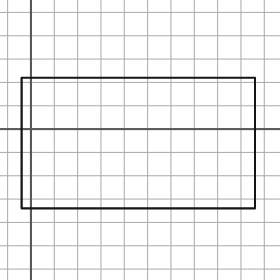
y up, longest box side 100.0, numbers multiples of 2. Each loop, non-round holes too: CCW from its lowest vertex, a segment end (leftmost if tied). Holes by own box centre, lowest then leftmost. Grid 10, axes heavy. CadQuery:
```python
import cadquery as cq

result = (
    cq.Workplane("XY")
    .moveTo(-4.0, -34.0)
    .lineTo(96.0, -34.0)
    .lineTo(96.0, 22.0)
    .lineTo(-4.0, 22.0)
    .close()
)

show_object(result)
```